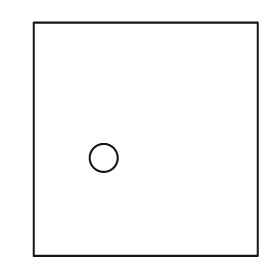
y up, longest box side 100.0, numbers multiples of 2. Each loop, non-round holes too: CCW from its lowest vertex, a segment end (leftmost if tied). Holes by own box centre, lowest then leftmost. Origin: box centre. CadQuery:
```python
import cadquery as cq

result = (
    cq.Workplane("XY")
    .moveTo(-48.0, -50.0)
    .lineTo(48.0, -50.0)
    .lineTo(48.0, 50.0)
    .lineTo(-48.0, 50.0)
    .close()
    .moveTo(-18.0, -8.0)
    .circle(6.0)
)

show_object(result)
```